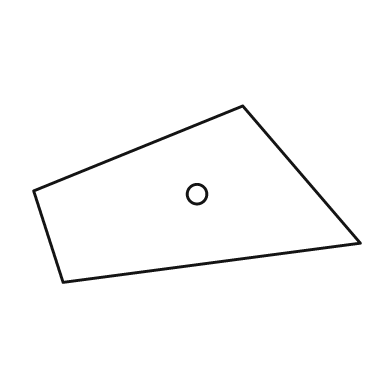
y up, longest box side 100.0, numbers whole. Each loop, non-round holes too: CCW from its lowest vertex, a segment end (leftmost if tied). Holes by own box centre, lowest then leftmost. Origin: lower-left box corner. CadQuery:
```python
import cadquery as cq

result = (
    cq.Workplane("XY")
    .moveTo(9.0, 0.0)
    .lineTo(100.0, 12.0)
    .lineTo(64.0, 54.0)
    .lineTo(0.0, 28.0)
    .close()
    .moveTo(50.0, 27.0)
    .circle(3.0)
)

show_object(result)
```